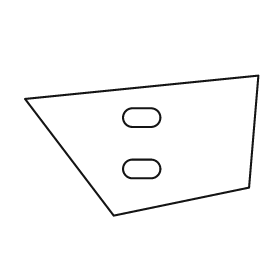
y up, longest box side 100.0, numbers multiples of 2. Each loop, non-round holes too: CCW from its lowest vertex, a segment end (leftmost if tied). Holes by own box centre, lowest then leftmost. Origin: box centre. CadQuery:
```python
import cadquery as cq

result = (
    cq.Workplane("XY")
    .moveTo(-12.0, -30.0)
    .lineTo(46.0, -18.0)
    .lineTo(50.0, 30.0)
    .lineTo(-50.0, 20.0)
    .close()
    .moveTo(-4.0, -14.0)
    .lineTo(4.0, -14.0)
    .threePointArc((8.0, -10.0), (4.0, -6.0))
    .lineTo(-4.0, -6.0)
    .threePointArc((-8.0, -10.0), (-4.0, -14.0))
    .close()
    .moveTo(-4.0, 8.0)
    .lineTo(4.0, 8.0)
    .threePointArc((8.0, 12.0), (4.0, 16.0))
    .lineTo(-4.0, 16.0)
    .threePointArc((-8.0, 12.0), (-4.0, 8.0))
    .close()
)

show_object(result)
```